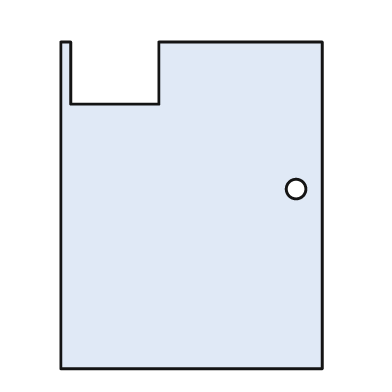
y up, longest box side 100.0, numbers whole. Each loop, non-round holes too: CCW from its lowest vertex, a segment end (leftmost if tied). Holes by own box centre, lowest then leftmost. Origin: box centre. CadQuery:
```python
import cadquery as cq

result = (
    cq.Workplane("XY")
    .moveTo(-40.0, -50.0)
    .lineTo(40.0, -50.0)
    .lineTo(40.0, 50.0)
    .lineTo(-10.0, 50.0)
    .lineTo(-10.0, 31.0)
    .lineTo(-37.0, 31.0)
    .lineTo(-37.0, 50.0)
    .lineTo(-40.0, 50.0)
    .close()
    .moveTo(32.0, 5.0)
    .circle(3.0)
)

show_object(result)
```